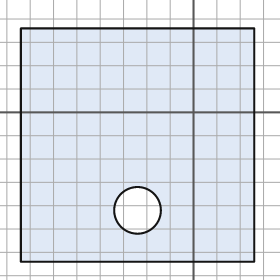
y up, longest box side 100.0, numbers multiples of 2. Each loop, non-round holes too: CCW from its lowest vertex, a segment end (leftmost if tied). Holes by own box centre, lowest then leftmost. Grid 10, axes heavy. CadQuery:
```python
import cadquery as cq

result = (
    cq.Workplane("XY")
    .moveTo(-74.0, -64.0)
    .lineTo(26.0, -64.0)
    .lineTo(26.0, 36.0)
    .lineTo(-74.0, 36.0)
    .close()
    .moveTo(-24.0, -42.0)
    .circle(10.0)
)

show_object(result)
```